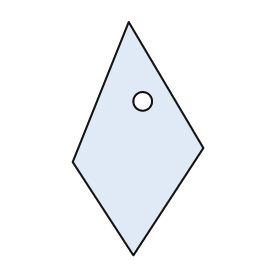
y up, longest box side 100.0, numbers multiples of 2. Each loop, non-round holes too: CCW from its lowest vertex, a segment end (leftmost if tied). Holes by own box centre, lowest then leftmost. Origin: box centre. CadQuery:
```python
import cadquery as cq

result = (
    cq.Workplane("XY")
    .moveTo(-2.0, -50.0)
    .lineTo(28.0, -4.0)
    .lineTo(-4.0, 50.0)
    .lineTo(-28.0, -10.0)
    .close()
    .moveTo(2.0, 16.0)
    .circle(4.0)
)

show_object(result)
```